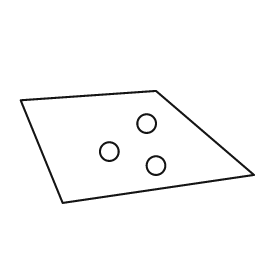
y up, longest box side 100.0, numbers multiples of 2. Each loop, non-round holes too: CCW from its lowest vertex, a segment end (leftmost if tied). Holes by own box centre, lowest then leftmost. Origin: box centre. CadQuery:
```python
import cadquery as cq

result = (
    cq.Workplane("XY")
    .moveTo(-32.0, -24.0)
    .lineTo(50.0, -12.0)
    .lineTo(8.0, 24.0)
    .lineTo(-50.0, 20.0)
    .close()
    .moveTo(8.0, -8.0)
    .circle(4.0)
    .moveTo(-12.0, -2.0)
    .circle(4.0)
    .moveTo(4.0, 10.0)
    .circle(4.0)
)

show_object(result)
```